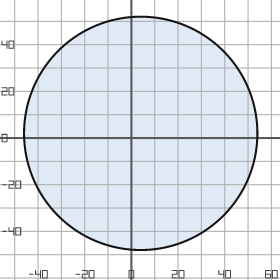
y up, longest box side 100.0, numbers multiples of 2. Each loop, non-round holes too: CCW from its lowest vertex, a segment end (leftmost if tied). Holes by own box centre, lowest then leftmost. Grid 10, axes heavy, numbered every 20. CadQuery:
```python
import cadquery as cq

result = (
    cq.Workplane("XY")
    .moveTo(4.0, 2.0)
    .circle(50.0)
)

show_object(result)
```